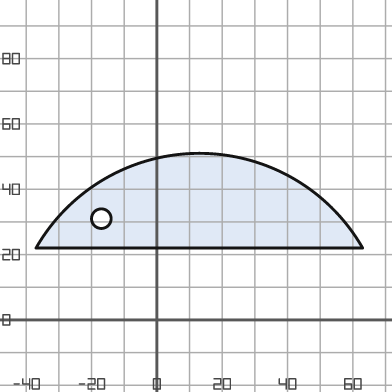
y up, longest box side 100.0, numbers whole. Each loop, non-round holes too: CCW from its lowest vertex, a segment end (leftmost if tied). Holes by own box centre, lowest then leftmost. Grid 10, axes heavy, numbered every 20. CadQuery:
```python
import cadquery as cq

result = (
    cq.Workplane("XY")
    .moveTo(-37.0, 22.0)
    .lineTo(63.0, 22.0)
    .threePointArc((13.0, 51.0), (-37.0, 22.0))
    .close()
    .moveTo(-17.0, 31.0)
    .circle(3.0)
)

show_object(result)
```